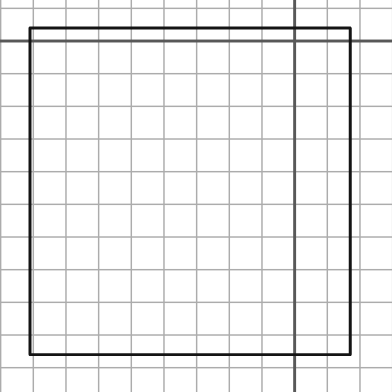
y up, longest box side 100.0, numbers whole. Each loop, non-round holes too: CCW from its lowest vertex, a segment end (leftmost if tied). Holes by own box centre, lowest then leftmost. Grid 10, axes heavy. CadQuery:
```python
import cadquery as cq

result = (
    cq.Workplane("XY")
    .moveTo(-81.0, -96.0)
    .lineTo(17.0, -96.0)
    .lineTo(17.0, 4.0)
    .lineTo(-81.0, 4.0)
    .close()
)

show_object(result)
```